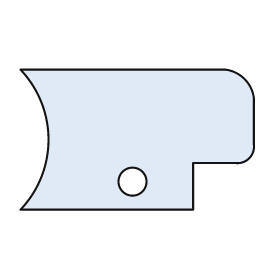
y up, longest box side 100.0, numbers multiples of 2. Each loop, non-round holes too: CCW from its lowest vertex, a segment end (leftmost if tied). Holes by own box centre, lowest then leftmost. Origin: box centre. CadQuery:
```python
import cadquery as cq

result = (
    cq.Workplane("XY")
    .moveTo(-50.0, -30.0)
    .lineTo(24.0, -30.0)
    .lineTo(24.0, -10.0)
    .lineTo(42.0, -10.0)
    .threePointArc((48.0, -8.0), (50.0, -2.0))
    .lineTo(50.0, 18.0)
    .threePointArc((46.0, 26.0), (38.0, 30.0))
    .lineTo(-50.0, 30.0)
    .threePointArc((-38.0, 0.0), (-50.0, -30.0))
    .close()
    .moveTo(-2.0, -18.0)
    .circle(6.0)
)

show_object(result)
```